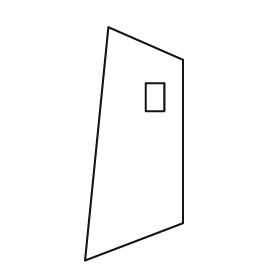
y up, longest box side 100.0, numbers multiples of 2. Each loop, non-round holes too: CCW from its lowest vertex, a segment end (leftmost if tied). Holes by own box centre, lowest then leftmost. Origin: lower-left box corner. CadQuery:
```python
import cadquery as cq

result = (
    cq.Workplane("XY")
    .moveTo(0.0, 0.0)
    .lineTo(42.0, 16.0)
    .lineTo(42.0, 86.0)
    .lineTo(10.0, 100.0)
    .close()
    .moveTo(26.0, 64.0)
    .lineTo(34.0, 64.0)
    .lineTo(34.0, 76.0)
    .lineTo(26.0, 76.0)
    .close()
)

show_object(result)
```